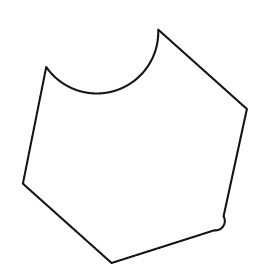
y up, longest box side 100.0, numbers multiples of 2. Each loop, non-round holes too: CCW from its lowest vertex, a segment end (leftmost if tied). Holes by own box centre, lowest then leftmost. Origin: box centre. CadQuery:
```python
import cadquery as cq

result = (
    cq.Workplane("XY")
    .moveTo(-10.0, -50.0)
    .lineTo(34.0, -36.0)
    .threePointArc((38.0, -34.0), (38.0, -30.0))
    .lineTo(48.0, 16.0)
    .lineTo(10.0, 50.0)
    .threePointArc((-8.0, 24.0), (-38.0, 34.0))
    .lineTo(-48.0, -16.0)
    .close()
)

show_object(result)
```